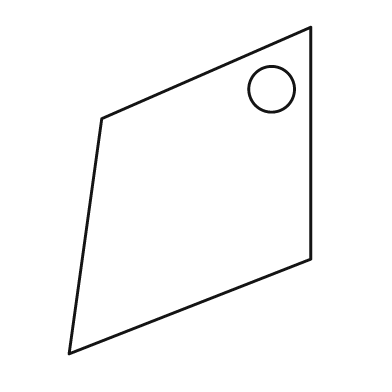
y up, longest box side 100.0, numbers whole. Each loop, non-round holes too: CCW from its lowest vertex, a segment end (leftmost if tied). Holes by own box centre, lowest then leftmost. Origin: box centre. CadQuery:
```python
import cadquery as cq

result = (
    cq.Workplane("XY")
    .moveTo(-37.0, -50.0)
    .lineTo(37.0, -21.0)
    .lineTo(37.0, 50.0)
    .lineTo(-27.0, 22.0)
    .close()
    .moveTo(25.0, 31.0)
    .circle(7.0)
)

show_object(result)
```